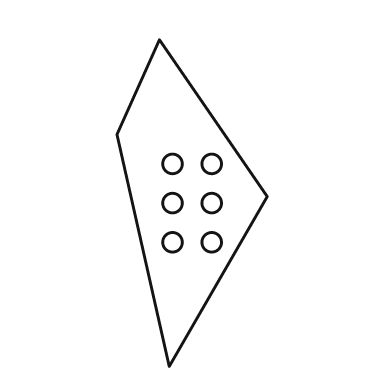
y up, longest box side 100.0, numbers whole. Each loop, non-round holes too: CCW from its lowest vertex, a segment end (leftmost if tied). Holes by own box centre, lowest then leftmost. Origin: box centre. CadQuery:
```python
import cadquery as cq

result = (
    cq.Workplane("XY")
    .moveTo(-7.0, -50.0)
    .lineTo(23.0, 2.0)
    .lineTo(-10.0, 50.0)
    .lineTo(-23.0, 21.0)
    .close()
    .moveTo(-6.0, -12.0)
    .circle(3.0)
    .moveTo(6.0, -12.0)
    .circle(3.0)
    .moveTo(-6.0, 0.0)
    .circle(3.0)
    .moveTo(6.0, 0.0)
    .circle(3.0)
    .moveTo(-6.0, 12.0)
    .circle(3.0)
    .moveTo(6.0, 12.0)
    .circle(3.0)
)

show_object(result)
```